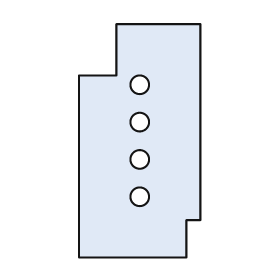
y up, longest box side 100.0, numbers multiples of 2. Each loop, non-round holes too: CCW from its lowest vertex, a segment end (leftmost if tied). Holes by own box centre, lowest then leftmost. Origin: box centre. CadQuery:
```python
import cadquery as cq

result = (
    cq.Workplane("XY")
    .moveTo(-26.0, -50.0)
    .lineTo(20.0, -50.0)
    .lineTo(20.0, -34.0)
    .lineTo(26.0, -34.0)
    .lineTo(26.0, 50.0)
    .lineTo(-10.0, 50.0)
    .lineTo(-10.0, 28.0)
    .lineTo(-26.0, 28.0)
    .close()
    .moveTo(0.0, -24.0)
    .circle(4.0)
    .moveTo(0.0, -8.0)
    .circle(4.0)
    .moveTo(0.0, 8.0)
    .circle(4.0)
    .moveTo(0.0, 24.0)
    .circle(4.0)
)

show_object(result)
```